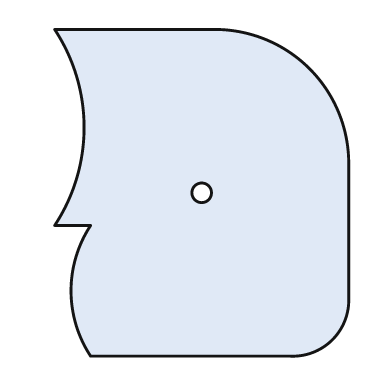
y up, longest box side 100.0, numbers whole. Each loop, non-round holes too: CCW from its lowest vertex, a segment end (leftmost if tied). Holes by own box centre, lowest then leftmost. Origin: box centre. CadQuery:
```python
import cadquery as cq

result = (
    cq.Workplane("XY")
    .moveTo(-34.0, -50.0)
    .lineTo(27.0, -50.0)
    .threePointArc((40.0, -45.0), (45.0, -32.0))
    .lineTo(45.0, 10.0)
    .threePointArc((33.0, 38.0), (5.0, 50.0))
    .lineTo(-45.0, 50.0)
    .threePointArc((-36.0, 20.0), (-45.0, -10.0))
    .lineTo(-34.0, -10.0)
    .threePointArc((-40.0, -30.0), (-34.0, -50.0))
    .close()
    .moveTo(0.0, 0.0)
    .circle(3.0)
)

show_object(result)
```